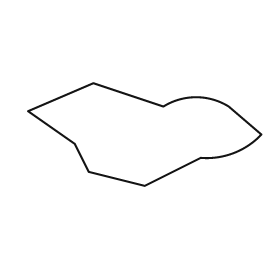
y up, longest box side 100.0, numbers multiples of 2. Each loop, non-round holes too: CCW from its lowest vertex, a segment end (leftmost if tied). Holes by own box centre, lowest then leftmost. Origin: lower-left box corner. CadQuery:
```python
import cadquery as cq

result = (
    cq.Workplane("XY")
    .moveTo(50.0, 0.0)
    .lineTo(74.0, 12.0)
    .threePointArc((88.0, 14.0), (100.0, 22.0))
    .lineTo(86.0, 34.0)
    .threePointArc((72.0, 38.0), (58.0, 34.0))
    .lineTo(28.0, 44.0)
    .lineTo(0.0, 32.0)
    .lineTo(20.0, 18.0)
    .lineTo(26.0, 6.0)
    .close()
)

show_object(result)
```